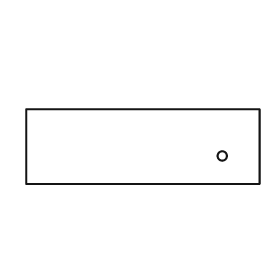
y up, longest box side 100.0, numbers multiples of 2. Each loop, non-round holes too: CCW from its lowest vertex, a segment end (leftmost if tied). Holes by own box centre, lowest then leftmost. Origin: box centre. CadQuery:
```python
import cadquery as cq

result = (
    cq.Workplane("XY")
    .moveTo(-50.0, -16.0)
    .lineTo(50.0, -16.0)
    .lineTo(50.0, 16.0)
    .lineTo(-50.0, 16.0)
    .close()
    .moveTo(34.0, -4.0)
    .circle(2.0)
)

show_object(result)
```